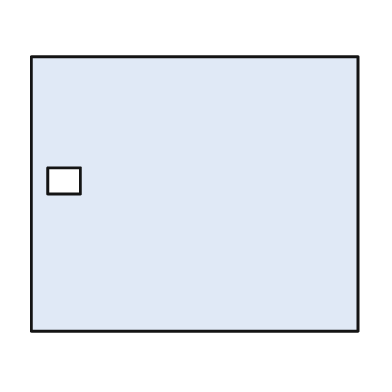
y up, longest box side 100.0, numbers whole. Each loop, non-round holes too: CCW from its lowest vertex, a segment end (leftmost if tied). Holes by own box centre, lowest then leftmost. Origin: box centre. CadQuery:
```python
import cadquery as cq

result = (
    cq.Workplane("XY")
    .moveTo(-50.0, -42.0)
    .lineTo(50.0, -42.0)
    .lineTo(50.0, 42.0)
    .lineTo(-50.0, 42.0)
    .close()
    .moveTo(-45.0, 0.0)
    .lineTo(-35.0, 0.0)
    .lineTo(-35.0, 8.0)
    .lineTo(-45.0, 8.0)
    .close()
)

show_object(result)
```